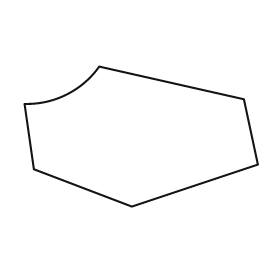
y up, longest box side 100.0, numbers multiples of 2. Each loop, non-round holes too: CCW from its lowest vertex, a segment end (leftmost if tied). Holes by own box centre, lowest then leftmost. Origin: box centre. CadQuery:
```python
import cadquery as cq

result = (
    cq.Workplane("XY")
    .moveTo(-4.0, -30.0)
    .lineTo(50.0, -12.0)
    .lineTo(44.0, 16.0)
    .lineTo(-18.0, 30.0)
    .threePointArc((-32.0, 18.0), (-50.0, 14.0))
    .lineTo(-46.0, -14.0)
    .close()
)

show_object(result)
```